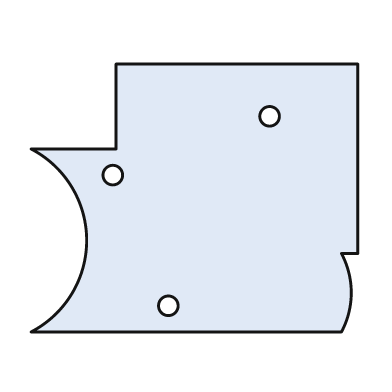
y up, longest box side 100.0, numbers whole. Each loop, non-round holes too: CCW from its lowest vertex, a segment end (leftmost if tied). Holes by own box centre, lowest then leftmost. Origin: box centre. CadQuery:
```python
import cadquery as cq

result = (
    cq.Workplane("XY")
    .moveTo(-50.0, -41.0)
    .lineTo(45.0, -41.0)
    .threePointArc((48.0, -29.0), (45.0, -17.0))
    .lineTo(50.0, -17.0)
    .lineTo(50.0, 41.0)
    .lineTo(-24.0, 41.0)
    .lineTo(-24.0, 15.0)
    .lineTo(-50.0, 15.0)
    .threePointArc((-33.0, -13.0), (-50.0, -41.0))
    .close()
    .moveTo(-8.0, -33.0)
    .circle(3.0)
    .moveTo(-25.0, 7.0)
    .circle(3.0)
    .moveTo(23.0, 25.0)
    .circle(3.0)
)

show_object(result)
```